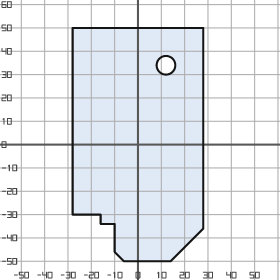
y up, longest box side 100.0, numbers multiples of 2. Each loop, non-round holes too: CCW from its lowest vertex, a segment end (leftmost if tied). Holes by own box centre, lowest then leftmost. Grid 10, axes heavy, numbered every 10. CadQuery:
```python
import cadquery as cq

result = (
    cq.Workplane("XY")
    .moveTo(-6.0, -50.0)
    .lineTo(14.0, -50.0)
    .lineTo(28.0, -36.0)
    .lineTo(28.0, 50.0)
    .lineTo(-28.0, 50.0)
    .lineTo(-28.0, -30.0)
    .lineTo(-16.0, -30.0)
    .lineTo(-16.0, -34.0)
    .lineTo(-10.0, -34.0)
    .lineTo(-10.0, -46.0)
    .close()
    .moveTo(12.0, 34.0)
    .circle(4.0)
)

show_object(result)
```